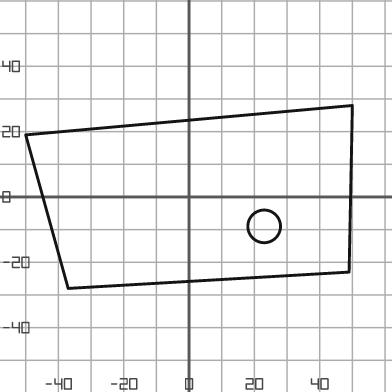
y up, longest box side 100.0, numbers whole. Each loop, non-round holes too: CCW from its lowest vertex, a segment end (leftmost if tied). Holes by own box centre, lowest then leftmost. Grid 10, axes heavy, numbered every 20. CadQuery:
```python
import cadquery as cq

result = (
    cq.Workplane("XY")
    .moveTo(-37.0, -28.0)
    .lineTo(49.0, -23.0)
    .lineTo(50.0, 28.0)
    .lineTo(-50.0, 19.0)
    .close()
    .moveTo(23.0, -9.0)
    .circle(5.0)
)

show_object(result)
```